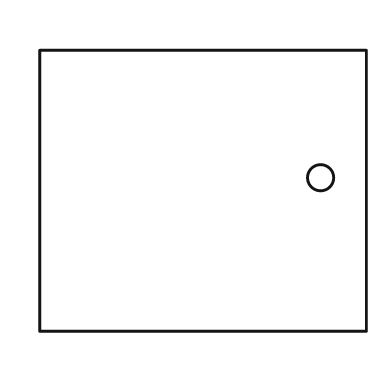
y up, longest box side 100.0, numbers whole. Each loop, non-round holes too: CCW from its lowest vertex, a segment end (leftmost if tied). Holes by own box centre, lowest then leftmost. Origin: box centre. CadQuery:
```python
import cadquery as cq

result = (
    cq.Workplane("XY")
    .moveTo(-50.0, -43.0)
    .lineTo(50.0, -43.0)
    .lineTo(50.0, 43.0)
    .lineTo(-50.0, 43.0)
    .close()
    .moveTo(36.0, 4.0)
    .circle(4.0)
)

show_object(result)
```